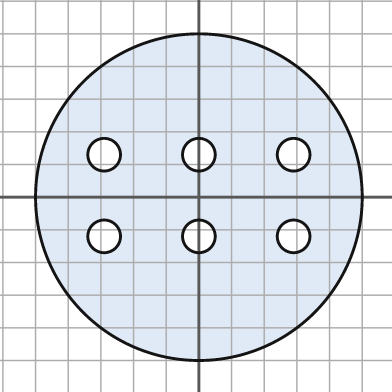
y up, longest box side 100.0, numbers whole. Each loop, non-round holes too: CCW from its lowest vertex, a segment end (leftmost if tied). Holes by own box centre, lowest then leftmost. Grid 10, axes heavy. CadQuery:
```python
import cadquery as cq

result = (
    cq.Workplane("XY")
    .moveTo(0.0, 0.0)
    .circle(50.0)
    .moveTo(-29.0, -12.0)
    .circle(5.0)
    .moveTo(0.0, -12.0)
    .circle(5.0)
    .moveTo(29.0, -12.0)
    .circle(5.0)
    .moveTo(-29.0, 13.0)
    .circle(5.0)
    .moveTo(0.0, 13.0)
    .circle(5.0)
    .moveTo(29.0, 13.0)
    .circle(5.0)
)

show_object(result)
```